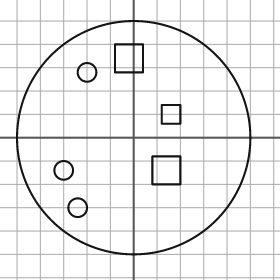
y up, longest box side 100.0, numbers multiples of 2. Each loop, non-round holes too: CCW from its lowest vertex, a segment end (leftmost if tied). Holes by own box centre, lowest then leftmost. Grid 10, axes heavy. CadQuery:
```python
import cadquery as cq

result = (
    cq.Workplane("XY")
    .moveTo(0.0, 0.0)
    .circle(50.0)
    .moveTo(-24.0, -30.0)
    .circle(4.0)
    .moveTo(-30.0, -14.0)
    .circle(4.0)
    .moveTo(8.0, -20.0)
    .lineTo(20.0, -20.0)
    .lineTo(20.0, -8.0)
    .lineTo(8.0, -8.0)
    .close()
    .moveTo(12.0, 6.0)
    .lineTo(20.0, 6.0)
    .lineTo(20.0, 14.0)
    .lineTo(12.0, 14.0)
    .close()
    .moveTo(-20.0, 28.0)
    .circle(4.0)
    .moveTo(-8.0, 28.0)
    .lineTo(4.0, 28.0)
    .lineTo(4.0, 40.0)
    .lineTo(-8.0, 40.0)
    .close()
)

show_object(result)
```